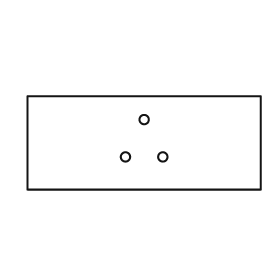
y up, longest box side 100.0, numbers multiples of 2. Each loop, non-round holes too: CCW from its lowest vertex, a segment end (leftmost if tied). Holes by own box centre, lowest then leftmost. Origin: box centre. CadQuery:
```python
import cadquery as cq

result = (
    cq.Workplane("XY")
    .moveTo(-50.0, -20.0)
    .lineTo(50.0, -20.0)
    .lineTo(50.0, 20.0)
    .lineTo(-50.0, 20.0)
    .close()
    .moveTo(-8.0, -6.0)
    .circle(2.0)
    .moveTo(8.0, -6.0)
    .circle(2.0)
    .moveTo(0.0, 10.0)
    .circle(2.0)
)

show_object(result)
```